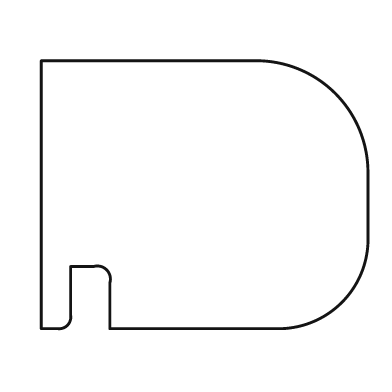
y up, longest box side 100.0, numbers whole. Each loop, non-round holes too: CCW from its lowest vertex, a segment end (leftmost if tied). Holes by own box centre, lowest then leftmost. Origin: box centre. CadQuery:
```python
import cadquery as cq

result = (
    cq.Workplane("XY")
    .moveTo(-50.0, -41.0)
    .lineTo(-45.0, -41.0)
    .threePointArc((-42.0, -40.0), (-41.0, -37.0))
    .lineTo(-41.0, -22.0)
    .lineTo(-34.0, -22.0)
    .threePointArc((-30.0, -23.0), (-29.0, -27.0))
    .lineTo(-29.0, -41.0)
    .lineTo(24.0, -41.0)
    .threePointArc((42.0, -33.0), (50.0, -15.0))
    .lineTo(50.0, 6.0)
    .threePointArc((40.0, 31.0), (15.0, 41.0))
    .lineTo(-50.0, 41.0)
    .close()
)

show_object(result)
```